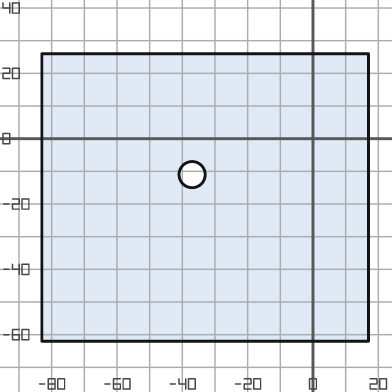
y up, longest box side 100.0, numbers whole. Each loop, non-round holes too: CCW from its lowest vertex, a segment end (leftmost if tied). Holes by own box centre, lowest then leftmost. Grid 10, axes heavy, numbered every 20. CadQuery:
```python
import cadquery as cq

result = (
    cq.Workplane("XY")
    .moveTo(-83.0, -62.0)
    .lineTo(17.0, -62.0)
    .lineTo(17.0, 26.0)
    .lineTo(-83.0, 26.0)
    .close()
    .moveTo(-37.0, -11.0)
    .circle(4.0)
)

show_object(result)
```